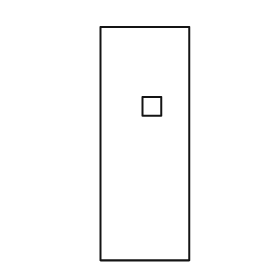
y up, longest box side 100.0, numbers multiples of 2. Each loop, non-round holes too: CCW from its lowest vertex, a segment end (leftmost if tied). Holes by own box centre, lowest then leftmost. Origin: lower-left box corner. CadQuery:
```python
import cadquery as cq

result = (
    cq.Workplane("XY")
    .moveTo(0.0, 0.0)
    .lineTo(38.0, 0.0)
    .lineTo(38.0, 100.0)
    .lineTo(0.0, 100.0)
    .close()
    .moveTo(18.0, 62.0)
    .lineTo(26.0, 62.0)
    .lineTo(26.0, 70.0)
    .lineTo(18.0, 70.0)
    .close()
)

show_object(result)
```